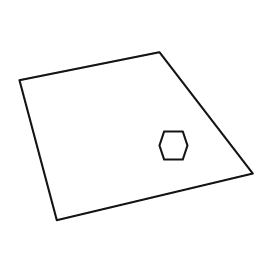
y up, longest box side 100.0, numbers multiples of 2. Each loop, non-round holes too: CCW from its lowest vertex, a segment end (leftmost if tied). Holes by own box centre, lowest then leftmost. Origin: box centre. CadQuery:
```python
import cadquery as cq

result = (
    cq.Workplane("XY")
    .moveTo(-34.0, -36.0)
    .lineTo(50.0, -16.0)
    .lineTo(10.0, 36.0)
    .lineTo(-50.0, 24.0)
    .close()
    .moveTo(12.0, -10.0)
    .lineTo(20.0, -10.0)
    .lineTo(22.0, -4.0)
    .lineTo(20.0, 2.0)
    .lineTo(12.0, 2.0)
    .lineTo(10.0, -4.0)
    .close()
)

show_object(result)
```